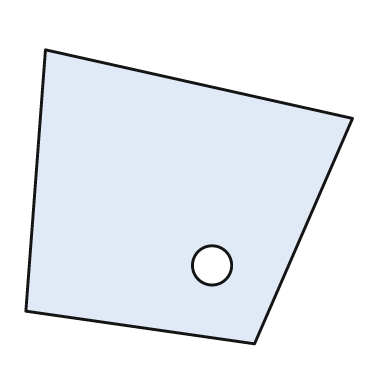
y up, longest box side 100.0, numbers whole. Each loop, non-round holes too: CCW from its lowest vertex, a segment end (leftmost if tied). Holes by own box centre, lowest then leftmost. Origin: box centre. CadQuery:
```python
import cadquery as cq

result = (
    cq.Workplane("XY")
    .moveTo(20.0, -45.0)
    .lineTo(50.0, 24.0)
    .lineTo(-44.0, 45.0)
    .lineTo(-50.0, -35.0)
    .close()
    .moveTo(7.0, -21.0)
    .circle(6.0)
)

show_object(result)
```